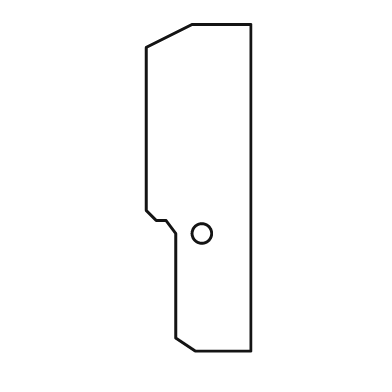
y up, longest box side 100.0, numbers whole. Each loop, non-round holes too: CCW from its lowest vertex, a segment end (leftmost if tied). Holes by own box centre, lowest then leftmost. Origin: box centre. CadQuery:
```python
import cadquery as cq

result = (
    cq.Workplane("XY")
    .moveTo(-1.0, -50.0)
    .lineTo(16.0, -50.0)
    .lineTo(16.0, 50.0)
    .lineTo(-2.0, 50.0)
    .lineTo(-16.0, 43.0)
    .lineTo(-16.0, -7.0)
    .lineTo(-13.0, -10.0)
    .lineTo(-10.0, -10.0)
    .lineTo(-7.0, -14.0)
    .lineTo(-7.0, -46.0)
    .close()
    .moveTo(1.0, -14.0)
    .circle(3.0)
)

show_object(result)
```